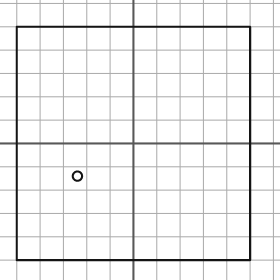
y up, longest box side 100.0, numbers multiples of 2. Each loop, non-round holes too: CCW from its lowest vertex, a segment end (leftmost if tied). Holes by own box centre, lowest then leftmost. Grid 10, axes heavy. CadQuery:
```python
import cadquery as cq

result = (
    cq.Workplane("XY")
    .moveTo(-50.0, -50.0)
    .lineTo(50.0, -50.0)
    .lineTo(50.0, 50.0)
    .lineTo(-50.0, 50.0)
    .close()
    .moveTo(-24.0, -14.0)
    .circle(2.0)
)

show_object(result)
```